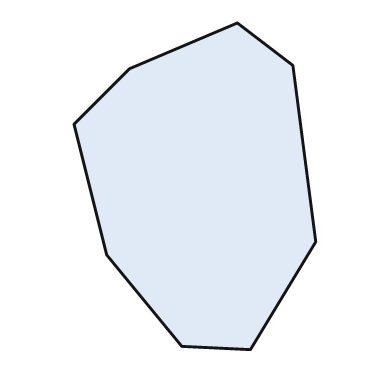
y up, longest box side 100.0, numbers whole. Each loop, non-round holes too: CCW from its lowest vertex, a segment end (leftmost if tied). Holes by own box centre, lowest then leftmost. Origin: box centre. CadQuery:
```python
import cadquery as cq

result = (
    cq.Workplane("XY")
    .moveTo(17.0, -50.0)
    .lineTo(37.0, -17.0)
    .lineTo(30.0, 37.0)
    .lineTo(13.0, 50.0)
    .lineTo(-20.0, 36.0)
    .lineTo(-37.0, 19.0)
    .lineTo(-27.0, -21.0)
    .lineTo(-4.0, -49.0)
    .close()
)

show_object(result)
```